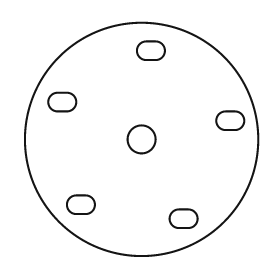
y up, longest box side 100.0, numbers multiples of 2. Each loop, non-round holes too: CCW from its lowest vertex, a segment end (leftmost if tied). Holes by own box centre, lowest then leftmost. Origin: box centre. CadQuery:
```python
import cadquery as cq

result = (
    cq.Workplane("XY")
    .moveTo(0.0, 0.0)
    .circle(50.0)
    .moveTo(16.0, -38.0)
    .lineTo(20.0, -38.0)
    .threePointArc((24.0, -34.0), (20.0, -30.0))
    .lineTo(16.0, -30.0)
    .threePointArc((12.0, -34.0), (16.0, -38.0))
    .close()
    .moveTo(-28.0, -32.0)
    .lineTo(-24.0, -32.0)
    .threePointArc((-20.0, -28.0), (-24.0, -24.0))
    .lineTo(-28.0, -24.0)
    .threePointArc((-32.0, -28.0), (-28.0, -32.0))
    .close()
    .moveTo(0.0, 0.0)
    .circle(6.0)
    .moveTo(36.0, 4.0)
    .lineTo(40.0, 4.0)
    .threePointArc((44.0, 8.0), (40.0, 12.0))
    .lineTo(36.0, 12.0)
    .threePointArc((32.0, 8.0), (36.0, 4.0))
    .close()
    .moveTo(-36.0, 12.0)
    .lineTo(-32.0, 12.0)
    .threePointArc((-28.0, 16.0), (-32.0, 20.0))
    .lineTo(-36.0, 20.0)
    .threePointArc((-40.0, 16.0), (-36.0, 12.0))
    .close()
    .moveTo(2.0, 34.0)
    .lineTo(6.0, 34.0)
    .threePointArc((10.0, 38.0), (6.0, 42.0))
    .lineTo(2.0, 42.0)
    .threePointArc((-2.0, 38.0), (2.0, 34.0))
    .close()
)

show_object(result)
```